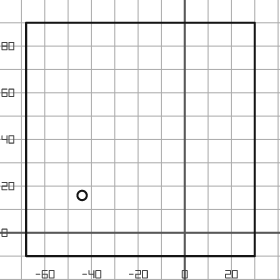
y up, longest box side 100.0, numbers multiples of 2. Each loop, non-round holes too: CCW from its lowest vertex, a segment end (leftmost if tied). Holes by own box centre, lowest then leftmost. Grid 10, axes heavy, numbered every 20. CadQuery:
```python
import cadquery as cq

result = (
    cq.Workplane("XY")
    .moveTo(-68.0, -10.0)
    .lineTo(30.0, -10.0)
    .lineTo(30.0, 90.0)
    .lineTo(-68.0, 90.0)
    .close()
    .moveTo(-44.0, 16.0)
    .circle(2.0)
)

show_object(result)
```